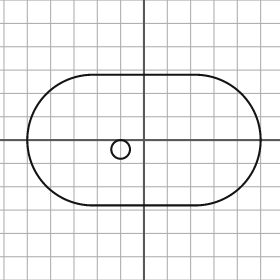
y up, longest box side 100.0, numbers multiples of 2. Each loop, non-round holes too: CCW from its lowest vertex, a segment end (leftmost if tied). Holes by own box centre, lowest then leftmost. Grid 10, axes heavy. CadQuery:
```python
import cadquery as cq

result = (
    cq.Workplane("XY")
    .moveTo(-22.0, -28.0)
    .lineTo(22.0, -28.0)
    .threePointArc((50.0, 0.0), (22.0, 28.0))
    .lineTo(-22.0, 28.0)
    .threePointArc((-50.0, 0.0), (-22.0, -28.0))
    .close()
    .moveTo(-10.0, -4.0)
    .circle(4.0)
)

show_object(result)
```